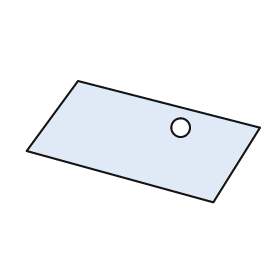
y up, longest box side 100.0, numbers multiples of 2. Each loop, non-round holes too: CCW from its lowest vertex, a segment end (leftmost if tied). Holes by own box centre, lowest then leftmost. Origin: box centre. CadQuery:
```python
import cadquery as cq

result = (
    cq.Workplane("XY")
    .moveTo(30.0, -26.0)
    .lineTo(50.0, 6.0)
    .lineTo(-28.0, 26.0)
    .lineTo(-50.0, -4.0)
    .close()
    .moveTo(16.0, 6.0)
    .circle(4.0)
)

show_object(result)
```